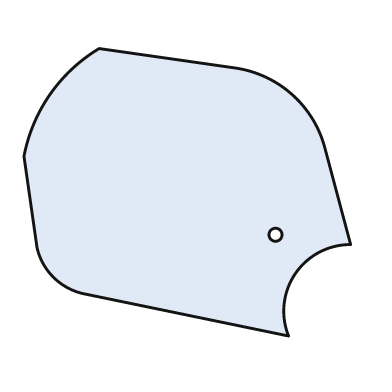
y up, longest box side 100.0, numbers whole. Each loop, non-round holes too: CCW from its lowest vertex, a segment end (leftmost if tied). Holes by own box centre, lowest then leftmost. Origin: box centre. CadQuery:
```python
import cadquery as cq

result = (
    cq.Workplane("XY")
    .moveTo(31.0, -44.0)
    .threePointArc((33.0, -25.0), (50.0, -16.0))
    .lineTo(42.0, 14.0)
    .threePointArc((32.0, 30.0), (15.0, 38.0))
    .lineTo(-27.0, 44.0)
    .threePointArc((-42.0, 30.0), (-50.0, 11.0))
    .lineTo(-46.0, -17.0)
    .threePointArc((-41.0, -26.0), (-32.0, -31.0))
    .close()
    .moveTo(27.0, -13.0)
    .circle(2.0)
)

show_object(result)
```